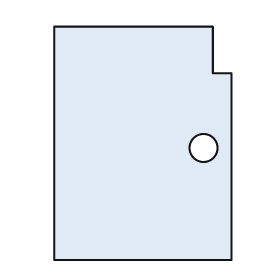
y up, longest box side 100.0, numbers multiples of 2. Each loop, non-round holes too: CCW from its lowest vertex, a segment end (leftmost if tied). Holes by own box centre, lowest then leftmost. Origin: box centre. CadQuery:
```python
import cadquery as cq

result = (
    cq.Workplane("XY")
    .moveTo(-38.0, -50.0)
    .lineTo(38.0, -50.0)
    .lineTo(38.0, 30.0)
    .lineTo(30.0, 30.0)
    .lineTo(30.0, 50.0)
    .lineTo(-38.0, 50.0)
    .close()
    .moveTo(26.0, -2.0)
    .circle(6.0)
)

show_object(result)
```